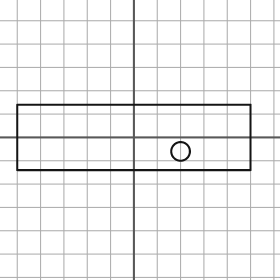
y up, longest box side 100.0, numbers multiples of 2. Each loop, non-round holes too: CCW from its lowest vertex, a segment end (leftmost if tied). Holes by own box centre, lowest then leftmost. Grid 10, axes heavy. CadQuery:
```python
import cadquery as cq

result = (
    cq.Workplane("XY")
    .moveTo(-50.0, -14.0)
    .lineTo(50.0, -14.0)
    .lineTo(50.0, 14.0)
    .lineTo(-50.0, 14.0)
    .close()
    .moveTo(20.0, -6.0)
    .circle(4.0)
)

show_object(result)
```